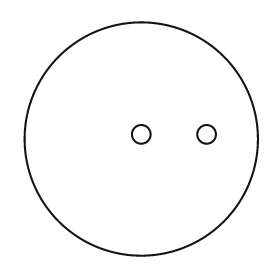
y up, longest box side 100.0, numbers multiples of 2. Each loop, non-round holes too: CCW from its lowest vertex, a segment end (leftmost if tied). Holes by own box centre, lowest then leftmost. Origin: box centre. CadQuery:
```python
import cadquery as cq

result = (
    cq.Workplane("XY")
    .moveTo(0.0, 0.0)
    .circle(50.0)
    .moveTo(0.0, 2.0)
    .circle(4.0)
    .moveTo(28.0, 2.0)
    .circle(4.0)
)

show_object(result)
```